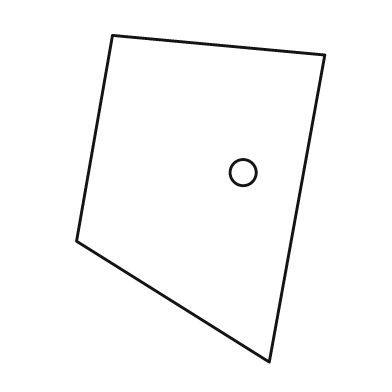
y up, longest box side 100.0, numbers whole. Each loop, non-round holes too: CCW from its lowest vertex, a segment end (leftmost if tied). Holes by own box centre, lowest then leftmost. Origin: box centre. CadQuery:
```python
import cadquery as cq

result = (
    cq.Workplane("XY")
    .moveTo(21.0, -50.0)
    .lineTo(38.0, 44.0)
    .lineTo(-27.0, 50.0)
    .lineTo(-38.0, -13.0)
    .close()
    .moveTo(13.0, 8.0)
    .circle(4.0)
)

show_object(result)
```